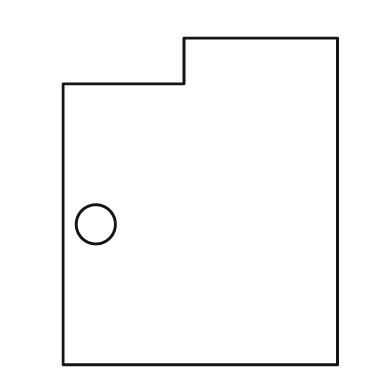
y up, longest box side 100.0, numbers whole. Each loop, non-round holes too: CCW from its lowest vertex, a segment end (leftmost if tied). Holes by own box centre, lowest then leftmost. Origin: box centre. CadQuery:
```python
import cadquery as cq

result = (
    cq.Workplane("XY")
    .moveTo(-42.0, -50.0)
    .lineTo(42.0, -50.0)
    .lineTo(42.0, 50.0)
    .lineTo(-5.0, 50.0)
    .lineTo(-5.0, 36.0)
    .lineTo(-42.0, 36.0)
    .close()
    .moveTo(-32.0, -7.0)
    .circle(6.0)
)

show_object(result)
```